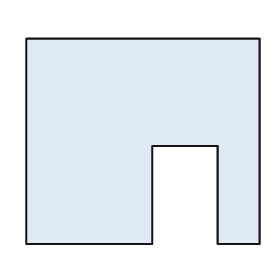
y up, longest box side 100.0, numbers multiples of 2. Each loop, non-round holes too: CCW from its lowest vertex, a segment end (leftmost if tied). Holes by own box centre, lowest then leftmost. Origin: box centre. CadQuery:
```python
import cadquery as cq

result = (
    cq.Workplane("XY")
    .moveTo(-50.0, -44.0)
    .lineTo(4.0, -44.0)
    .lineTo(4.0, -2.0)
    .lineTo(32.0, -2.0)
    .lineTo(32.0, -44.0)
    .lineTo(50.0, -44.0)
    .lineTo(50.0, 44.0)
    .lineTo(-50.0, 44.0)
    .close()
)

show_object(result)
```